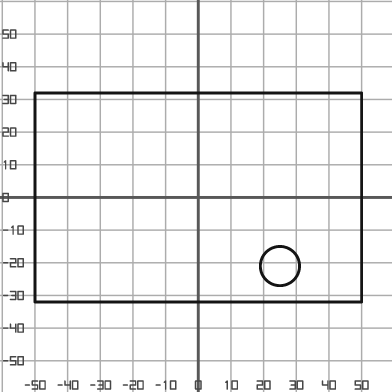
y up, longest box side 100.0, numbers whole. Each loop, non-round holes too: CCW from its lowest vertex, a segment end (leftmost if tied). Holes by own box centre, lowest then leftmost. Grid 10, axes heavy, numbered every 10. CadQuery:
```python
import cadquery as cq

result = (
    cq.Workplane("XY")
    .moveTo(-50.0, -32.0)
    .lineTo(50.0, -32.0)
    .lineTo(50.0, 32.0)
    .lineTo(-50.0, 32.0)
    .close()
    .moveTo(25.0, -21.0)
    .circle(6.0)
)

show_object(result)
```